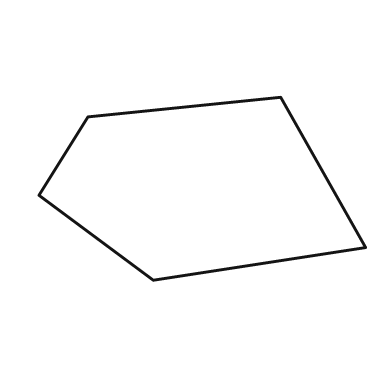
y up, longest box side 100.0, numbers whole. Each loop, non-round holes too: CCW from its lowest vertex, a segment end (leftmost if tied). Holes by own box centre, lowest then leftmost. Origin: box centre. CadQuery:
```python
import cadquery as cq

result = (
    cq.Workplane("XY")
    .moveTo(-15.0, -28.0)
    .lineTo(50.0, -18.0)
    .lineTo(24.0, 28.0)
    .lineTo(-35.0, 22.0)
    .lineTo(-50.0, -2.0)
    .close()
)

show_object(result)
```